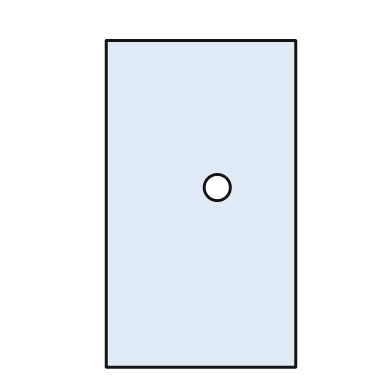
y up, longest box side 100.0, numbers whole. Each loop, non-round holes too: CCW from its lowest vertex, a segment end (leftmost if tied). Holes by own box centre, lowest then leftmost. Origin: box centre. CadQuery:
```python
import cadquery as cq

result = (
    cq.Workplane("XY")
    .moveTo(-29.0, -50.0)
    .lineTo(29.0, -50.0)
    .lineTo(29.0, 50.0)
    .lineTo(-29.0, 50.0)
    .close()
    .moveTo(5.0, 5.0)
    .circle(4.0)
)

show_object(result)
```